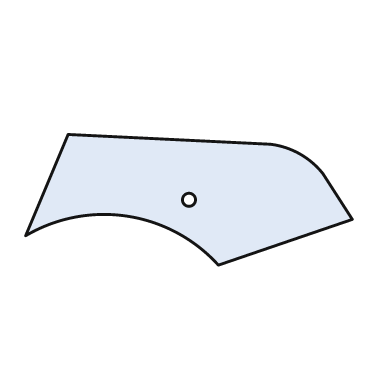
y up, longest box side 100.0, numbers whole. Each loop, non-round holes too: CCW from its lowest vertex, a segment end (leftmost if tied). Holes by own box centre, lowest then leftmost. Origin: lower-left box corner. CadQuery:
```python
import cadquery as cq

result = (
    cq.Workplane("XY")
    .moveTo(59.0, 0.0)
    .lineTo(100.0, 14.0)
    .lineTo(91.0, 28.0)
    .threePointArc((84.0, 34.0), (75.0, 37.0))
    .lineTo(13.0, 40.0)
    .lineTo(0.0, 9.0)
    .threePointArc((31.0, 15.0), (59.0, 0.0))
    .close()
    .moveTo(50.0, 20.0)
    .circle(2.0)
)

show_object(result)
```